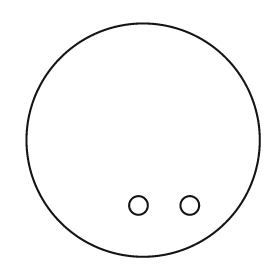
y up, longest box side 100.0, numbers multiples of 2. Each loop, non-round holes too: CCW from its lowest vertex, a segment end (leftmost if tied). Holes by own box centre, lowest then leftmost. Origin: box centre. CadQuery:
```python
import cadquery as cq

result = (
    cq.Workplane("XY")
    .moveTo(0.0, 0.0)
    .circle(50.0)
    .moveTo(-2.0, -28.0)
    .circle(4.0)
    .moveTo(20.0, -28.0)
    .circle(4.0)
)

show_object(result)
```